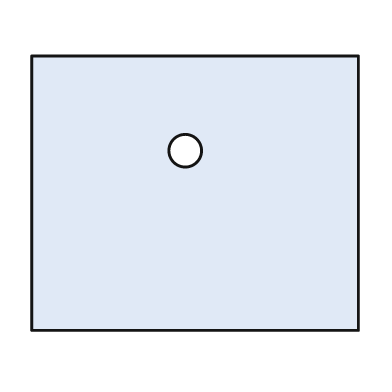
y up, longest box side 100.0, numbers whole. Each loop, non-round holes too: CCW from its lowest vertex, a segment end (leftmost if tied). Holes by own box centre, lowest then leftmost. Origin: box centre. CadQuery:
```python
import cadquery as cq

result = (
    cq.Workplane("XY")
    .moveTo(-50.0, -42.0)
    .lineTo(50.0, -42.0)
    .lineTo(50.0, 42.0)
    .lineTo(-50.0, 42.0)
    .close()
    .moveTo(-3.0, 13.0)
    .circle(5.0)
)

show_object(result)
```